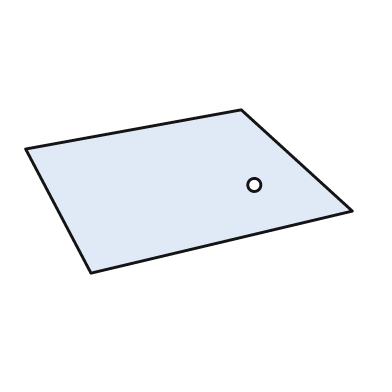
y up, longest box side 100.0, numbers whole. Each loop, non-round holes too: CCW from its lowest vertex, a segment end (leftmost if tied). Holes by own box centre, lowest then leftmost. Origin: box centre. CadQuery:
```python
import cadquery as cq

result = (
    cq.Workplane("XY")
    .moveTo(-30.0, -25.0)
    .lineTo(50.0, -6.0)
    .lineTo(16.0, 25.0)
    .lineTo(-50.0, 13.0)
    .close()
    .moveTo(20.0, 2.0)
    .circle(2.0)
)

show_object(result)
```